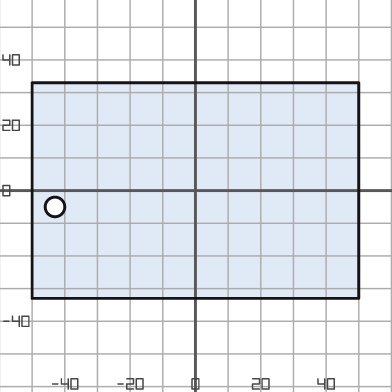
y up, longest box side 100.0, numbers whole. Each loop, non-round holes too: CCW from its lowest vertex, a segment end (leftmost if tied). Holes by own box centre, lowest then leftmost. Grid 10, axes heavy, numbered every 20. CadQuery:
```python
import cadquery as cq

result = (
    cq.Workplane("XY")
    .moveTo(-50.0, -33.0)
    .lineTo(50.0, -33.0)
    .lineTo(50.0, 33.0)
    .lineTo(-50.0, 33.0)
    .close()
    .moveTo(-43.0, -5.0)
    .circle(3.0)
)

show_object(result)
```